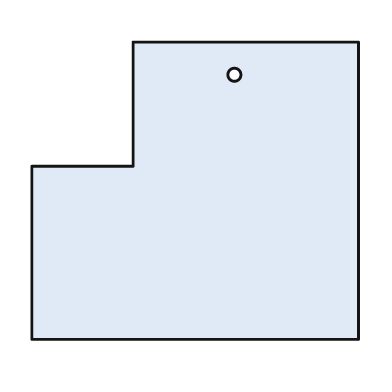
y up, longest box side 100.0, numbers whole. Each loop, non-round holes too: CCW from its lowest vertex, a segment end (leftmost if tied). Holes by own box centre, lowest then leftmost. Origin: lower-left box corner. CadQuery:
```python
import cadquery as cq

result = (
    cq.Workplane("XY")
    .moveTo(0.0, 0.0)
    .lineTo(100.0, 0.0)
    .lineTo(100.0, 91.0)
    .lineTo(31.0, 91.0)
    .lineTo(31.0, 53.0)
    .lineTo(0.0, 53.0)
    .close()
    .moveTo(62.0, 81.0)
    .circle(2.0)
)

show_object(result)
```